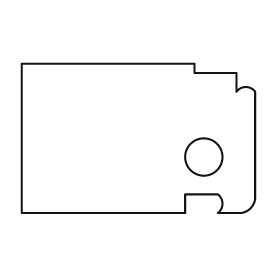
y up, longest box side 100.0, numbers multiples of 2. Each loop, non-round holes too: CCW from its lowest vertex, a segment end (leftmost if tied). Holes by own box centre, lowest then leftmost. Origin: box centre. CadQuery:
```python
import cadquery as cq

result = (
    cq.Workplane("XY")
    .moveTo(-50.0, -32.0)
    .lineTo(20.0, -32.0)
    .lineTo(20.0, -24.0)
    .lineTo(34.0, -24.0)
    .threePointArc((36.0, -28.0), (34.0, -32.0))
    .lineTo(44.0, -32.0)
    .threePointArc((48.0, -30.0), (50.0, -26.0))
    .lineTo(50.0, 20.0)
    .threePointArc((46.0, 22.0), (42.0, 20.0))
    .lineTo(42.0, 28.0)
    .lineTo(24.0, 28.0)
    .lineTo(24.0, 32.0)
    .lineTo(-50.0, 32.0)
    .close()
    .moveTo(28.0, -8.0)
    .circle(8.0)
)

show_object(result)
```